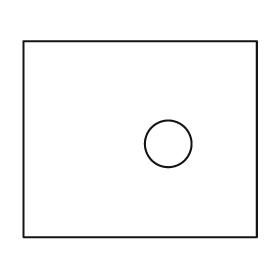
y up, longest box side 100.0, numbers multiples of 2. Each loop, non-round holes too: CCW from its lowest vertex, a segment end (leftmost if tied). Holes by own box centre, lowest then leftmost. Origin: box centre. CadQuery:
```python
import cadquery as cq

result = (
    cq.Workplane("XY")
    .moveTo(-50.0, -42.0)
    .lineTo(50.0, -42.0)
    .lineTo(50.0, 42.0)
    .lineTo(-50.0, 42.0)
    .close()
    .moveTo(12.0, -2.0)
    .circle(10.0)
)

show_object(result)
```